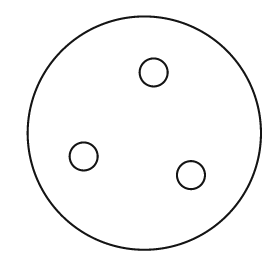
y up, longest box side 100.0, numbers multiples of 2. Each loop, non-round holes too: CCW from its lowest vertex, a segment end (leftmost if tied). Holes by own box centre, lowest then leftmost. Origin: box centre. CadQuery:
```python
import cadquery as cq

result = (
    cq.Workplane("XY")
    .moveTo(0.0, 0.0)
    .circle(50.0)
    .moveTo(20.0, -18.0)
    .circle(6.0)
    .moveTo(-26.0, -10.0)
    .circle(6.0)
    .moveTo(4.0, 26.0)
    .circle(6.0)
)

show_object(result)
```